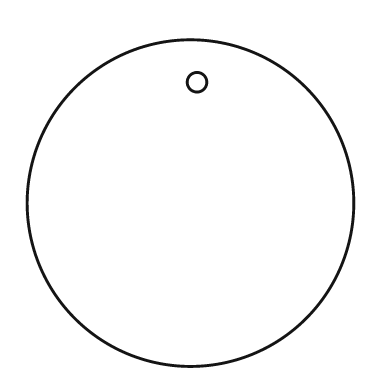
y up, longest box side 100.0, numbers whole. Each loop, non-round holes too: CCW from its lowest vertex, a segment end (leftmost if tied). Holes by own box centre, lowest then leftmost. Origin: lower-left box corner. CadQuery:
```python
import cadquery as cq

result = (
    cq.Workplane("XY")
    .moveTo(50.0, 50.0)
    .circle(50.0)
    .moveTo(52.0, 87.0)
    .circle(3.0)
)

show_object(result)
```